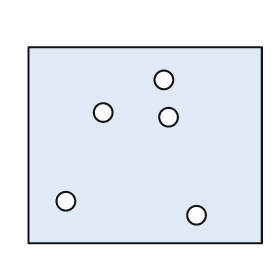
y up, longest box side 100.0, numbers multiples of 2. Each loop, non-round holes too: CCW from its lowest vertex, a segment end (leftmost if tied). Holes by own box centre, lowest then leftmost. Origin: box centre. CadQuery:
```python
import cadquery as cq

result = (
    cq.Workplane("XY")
    .moveTo(-50.0, -42.0)
    .lineTo(50.0, -42.0)
    .lineTo(50.0, 42.0)
    .lineTo(-50.0, 42.0)
    .close()
    .moveTo(22.0, -30.0)
    .circle(4.0)
    .moveTo(-34.0, -24.0)
    .circle(4.0)
    .moveTo(10.0, 12.0)
    .circle(4.0)
    .moveTo(-18.0, 14.0)
    .circle(4.0)
    .moveTo(8.0, 28.0)
    .circle(4.0)
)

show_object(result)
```